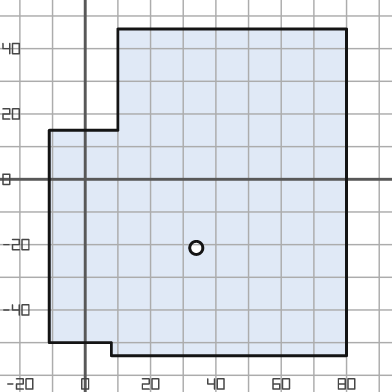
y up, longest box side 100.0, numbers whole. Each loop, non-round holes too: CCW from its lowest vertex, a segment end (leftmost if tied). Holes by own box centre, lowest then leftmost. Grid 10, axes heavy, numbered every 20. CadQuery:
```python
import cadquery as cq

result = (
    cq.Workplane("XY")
    .moveTo(8.0, -54.0)
    .lineTo(80.0, -54.0)
    .lineTo(80.0, 46.0)
    .lineTo(10.0, 46.0)
    .lineTo(10.0, 15.0)
    .lineTo(-11.0, 15.0)
    .lineTo(-11.0, -50.0)
    .lineTo(8.0, -50.0)
    .close()
    .moveTo(34.0, -21.0)
    .circle(2.0)
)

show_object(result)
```